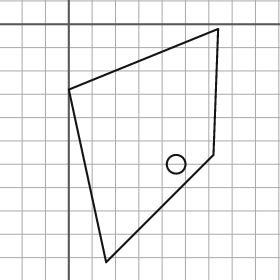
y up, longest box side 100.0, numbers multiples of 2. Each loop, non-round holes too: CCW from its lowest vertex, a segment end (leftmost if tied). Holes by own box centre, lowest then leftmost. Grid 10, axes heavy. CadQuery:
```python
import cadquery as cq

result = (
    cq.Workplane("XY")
    .moveTo(16.0, -102.0)
    .lineTo(62.0, -56.0)
    .lineTo(64.0, -2.0)
    .lineTo(0.0, -28.0)
    .close()
    .moveTo(46.0, -60.0)
    .circle(4.0)
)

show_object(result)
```